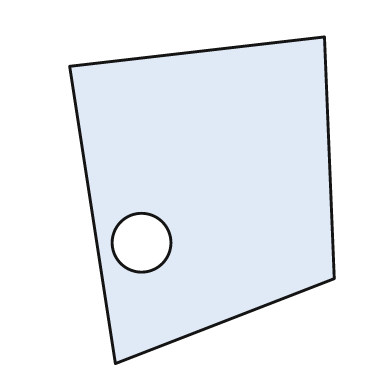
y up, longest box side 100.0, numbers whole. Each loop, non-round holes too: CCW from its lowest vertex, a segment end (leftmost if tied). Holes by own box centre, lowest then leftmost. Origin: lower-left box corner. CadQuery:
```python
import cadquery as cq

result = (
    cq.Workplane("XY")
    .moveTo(14.0, 0.0)
    .lineTo(81.0, 26.0)
    .lineTo(78.0, 100.0)
    .lineTo(0.0, 91.0)
    .close()
    .moveTo(22.0, 37.0)
    .circle(9.0)
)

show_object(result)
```